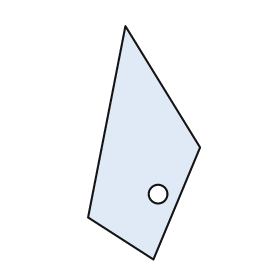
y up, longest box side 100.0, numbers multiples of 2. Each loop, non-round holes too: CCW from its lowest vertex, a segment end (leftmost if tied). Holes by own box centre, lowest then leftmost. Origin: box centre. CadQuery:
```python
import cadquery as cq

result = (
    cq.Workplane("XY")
    .moveTo(4.0, -50.0)
    .lineTo(24.0, -2.0)
    .lineTo(-8.0, 50.0)
    .lineTo(-24.0, -32.0)
    .close()
    .moveTo(6.0, -22.0)
    .circle(4.0)
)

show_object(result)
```